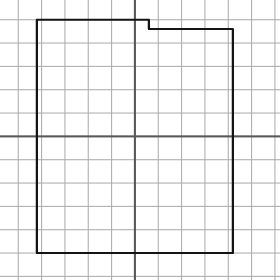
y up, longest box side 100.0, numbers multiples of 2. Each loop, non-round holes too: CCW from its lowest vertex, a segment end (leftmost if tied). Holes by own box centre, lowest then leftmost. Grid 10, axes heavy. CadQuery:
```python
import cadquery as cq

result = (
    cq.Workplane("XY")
    .moveTo(-42.0, -50.0)
    .lineTo(42.0, -50.0)
    .lineTo(42.0, 46.0)
    .lineTo(6.0, 46.0)
    .lineTo(6.0, 50.0)
    .lineTo(-42.0, 50.0)
    .close()
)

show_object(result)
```